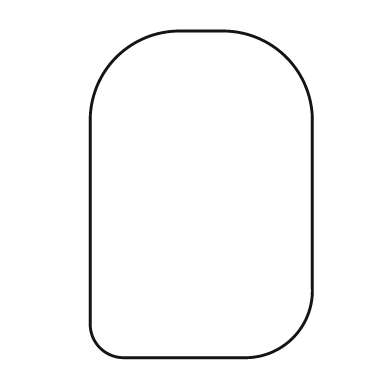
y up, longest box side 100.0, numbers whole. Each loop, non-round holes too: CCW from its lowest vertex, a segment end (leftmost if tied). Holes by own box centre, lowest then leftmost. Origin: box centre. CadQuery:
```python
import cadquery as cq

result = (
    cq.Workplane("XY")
    .moveTo(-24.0, -50.0)
    .lineTo(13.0, -50.0)
    .threePointArc((28.0, -44.0), (34.0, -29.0))
    .lineTo(34.0, 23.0)
    .threePointArc((26.0, 42.0), (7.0, 50.0))
    .lineTo(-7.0, 50.0)
    .threePointArc((-26.0, 42.0), (-34.0, 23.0))
    .lineTo(-34.0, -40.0)
    .threePointArc((-31.0, -47.0), (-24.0, -50.0))
    .close()
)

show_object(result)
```